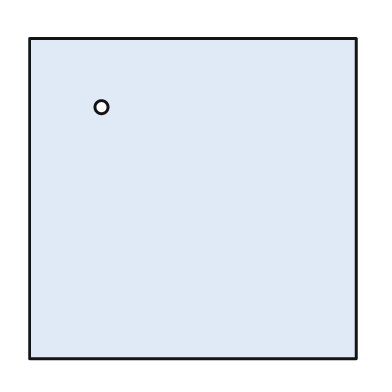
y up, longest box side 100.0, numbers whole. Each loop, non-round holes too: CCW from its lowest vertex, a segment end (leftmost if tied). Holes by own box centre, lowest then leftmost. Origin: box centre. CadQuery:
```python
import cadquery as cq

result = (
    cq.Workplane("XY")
    .moveTo(-50.0, -49.0)
    .lineTo(50.0, -49.0)
    .lineTo(50.0, 49.0)
    .lineTo(-50.0, 49.0)
    .close()
    .moveTo(-28.0, 28.0)
    .circle(2.0)
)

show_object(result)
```